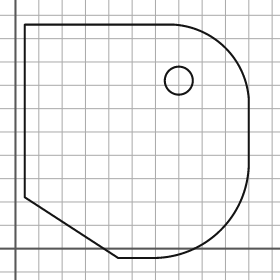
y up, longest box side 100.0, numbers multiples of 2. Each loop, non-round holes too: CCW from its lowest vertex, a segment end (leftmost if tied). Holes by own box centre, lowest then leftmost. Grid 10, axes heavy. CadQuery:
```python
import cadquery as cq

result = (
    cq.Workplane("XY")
    .moveTo(44.0, -4.0)
    .lineTo(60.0, -4.0)
    .threePointArc((88.0, 8.0), (100.0, 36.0))
    .lineTo(100.0, 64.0)
    .threePointArc((90.0, 86.0), (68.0, 96.0))
    .lineTo(4.0, 96.0)
    .lineTo(4.0, 22.0)
    .close()
    .moveTo(70.0, 72.0)
    .circle(6.0)
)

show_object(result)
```